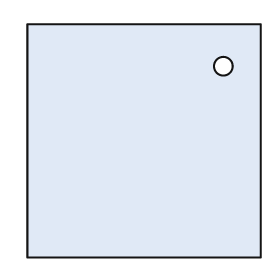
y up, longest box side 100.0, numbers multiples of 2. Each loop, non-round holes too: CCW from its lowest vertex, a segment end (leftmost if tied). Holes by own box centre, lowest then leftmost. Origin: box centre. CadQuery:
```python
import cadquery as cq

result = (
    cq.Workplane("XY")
    .moveTo(-50.0, -50.0)
    .lineTo(50.0, -50.0)
    .lineTo(50.0, 50.0)
    .lineTo(-50.0, 50.0)
    .close()
    .moveTo(34.0, 32.0)
    .circle(4.0)
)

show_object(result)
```